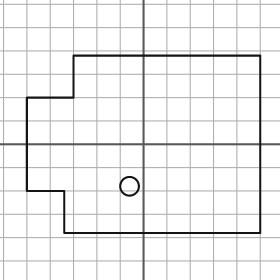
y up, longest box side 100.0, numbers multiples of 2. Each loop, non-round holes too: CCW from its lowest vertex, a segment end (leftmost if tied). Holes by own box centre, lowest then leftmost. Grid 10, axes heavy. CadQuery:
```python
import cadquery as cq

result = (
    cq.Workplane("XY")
    .moveTo(-34.0, -38.0)
    .lineTo(50.0, -38.0)
    .lineTo(50.0, 38.0)
    .lineTo(-30.0, 38.0)
    .lineTo(-30.0, 20.0)
    .lineTo(-50.0, 20.0)
    .lineTo(-50.0, -20.0)
    .lineTo(-34.0, -20.0)
    .close()
    .moveTo(-6.0, -18.0)
    .circle(4.0)
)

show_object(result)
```